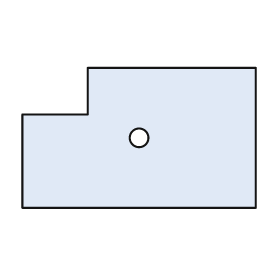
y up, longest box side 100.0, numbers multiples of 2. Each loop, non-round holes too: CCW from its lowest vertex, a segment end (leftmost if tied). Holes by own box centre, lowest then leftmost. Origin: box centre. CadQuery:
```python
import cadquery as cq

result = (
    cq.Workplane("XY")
    .moveTo(-50.0, -30.0)
    .lineTo(50.0, -30.0)
    .lineTo(50.0, 30.0)
    .lineTo(-22.0, 30.0)
    .lineTo(-22.0, 10.0)
    .lineTo(-50.0, 10.0)
    .close()
    .moveTo(0.0, 0.0)
    .circle(4.0)
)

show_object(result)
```